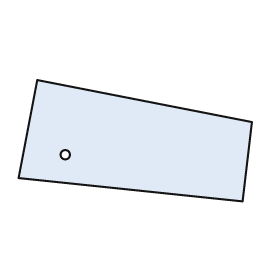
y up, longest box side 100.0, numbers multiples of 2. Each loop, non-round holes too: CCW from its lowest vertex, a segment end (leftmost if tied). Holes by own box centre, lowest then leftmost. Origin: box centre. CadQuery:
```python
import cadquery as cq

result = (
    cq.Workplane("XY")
    .moveTo(46.0, -26.0)
    .lineTo(50.0, 8.0)
    .lineTo(-42.0, 26.0)
    .lineTo(-50.0, -16.0)
    .close()
    .moveTo(-30.0, -6.0)
    .circle(2.0)
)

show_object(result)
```